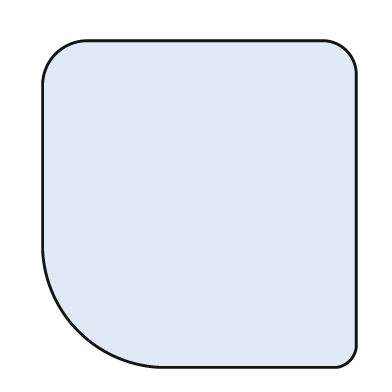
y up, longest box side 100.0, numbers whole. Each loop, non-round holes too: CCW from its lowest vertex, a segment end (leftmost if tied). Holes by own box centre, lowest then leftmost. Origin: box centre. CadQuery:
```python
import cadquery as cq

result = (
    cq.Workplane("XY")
    .moveTo(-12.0, -50.0)
    .lineTo(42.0, -50.0)
    .threePointArc((46.0, -48.0), (48.0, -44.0))
    .lineTo(48.0, 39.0)
    .threePointArc((45.0, 47.0), (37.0, 50.0))
    .lineTo(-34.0, 50.0)
    .threePointArc((-44.0, 46.0), (-48.0, 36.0))
    .lineTo(-48.0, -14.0)
    .threePointArc((-37.0, -39.0), (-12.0, -50.0))
    .close()
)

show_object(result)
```